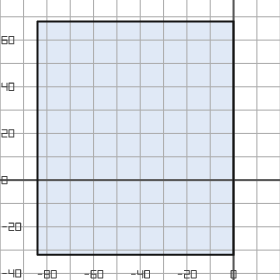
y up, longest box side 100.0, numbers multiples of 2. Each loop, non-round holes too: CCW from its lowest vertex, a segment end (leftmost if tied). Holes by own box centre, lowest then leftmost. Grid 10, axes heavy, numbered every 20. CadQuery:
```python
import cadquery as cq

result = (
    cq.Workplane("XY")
    .moveTo(-84.0, -32.0)
    .lineTo(0.0, -32.0)
    .lineTo(0.0, 68.0)
    .lineTo(-84.0, 68.0)
    .close()
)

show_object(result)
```